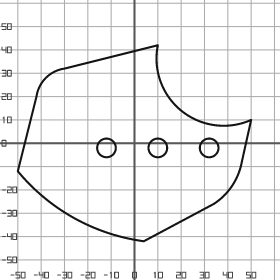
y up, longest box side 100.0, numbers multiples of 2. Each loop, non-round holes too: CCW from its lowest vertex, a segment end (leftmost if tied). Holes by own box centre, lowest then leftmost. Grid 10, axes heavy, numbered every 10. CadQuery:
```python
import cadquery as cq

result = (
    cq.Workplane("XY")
    .moveTo(4.0, -42.0)
    .lineTo(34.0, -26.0)
    .threePointArc((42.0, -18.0), (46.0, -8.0))
    .lineTo(50.0, 10.0)
    .threePointArc((20.0, 14.0), (10.0, 42.0))
    .lineTo(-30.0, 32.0)
    .threePointArc((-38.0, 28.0), (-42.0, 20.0))
    .lineTo(-50.0, -12.0)
    .threePointArc((-26.0, -32.0), (4.0, -42.0))
    .close()
    .moveTo(-12.0, -2.0)
    .circle(4.0)
    .moveTo(10.0, -2.0)
    .circle(4.0)
    .moveTo(32.0, -2.0)
    .circle(4.0)
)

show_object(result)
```